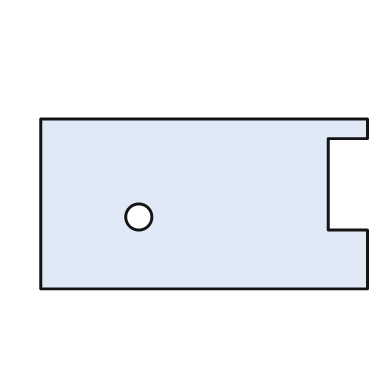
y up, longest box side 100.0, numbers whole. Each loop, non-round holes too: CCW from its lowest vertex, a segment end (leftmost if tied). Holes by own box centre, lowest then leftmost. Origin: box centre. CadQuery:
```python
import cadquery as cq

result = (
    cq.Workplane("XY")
    .moveTo(-50.0, -26.0)
    .lineTo(50.0, -26.0)
    .lineTo(50.0, -8.0)
    .lineTo(38.0, -8.0)
    .lineTo(38.0, 20.0)
    .lineTo(50.0, 20.0)
    .lineTo(50.0, 26.0)
    .lineTo(-50.0, 26.0)
    .close()
    .moveTo(-20.0, -4.0)
    .circle(4.0)
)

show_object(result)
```